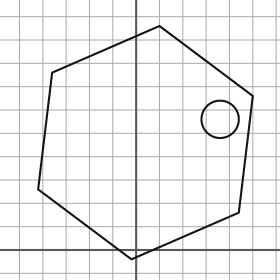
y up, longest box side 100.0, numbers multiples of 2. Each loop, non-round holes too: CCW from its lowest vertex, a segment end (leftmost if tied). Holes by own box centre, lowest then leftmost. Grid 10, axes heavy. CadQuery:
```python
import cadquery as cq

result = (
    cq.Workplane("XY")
    .moveTo(-2.0, -4.0)
    .lineTo(44.0, 16.0)
    .lineTo(50.0, 66.0)
    .lineTo(10.0, 96.0)
    .lineTo(-36.0, 76.0)
    .lineTo(-42.0, 26.0)
    .close()
    .moveTo(36.0, 56.0)
    .circle(8.0)
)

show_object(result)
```